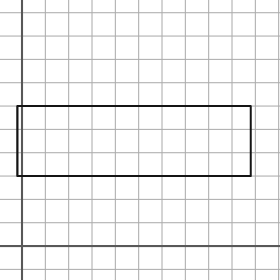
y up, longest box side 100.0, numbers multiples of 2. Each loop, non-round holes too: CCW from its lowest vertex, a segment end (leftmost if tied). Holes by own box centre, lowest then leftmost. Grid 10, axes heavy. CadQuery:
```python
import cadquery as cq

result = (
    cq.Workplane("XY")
    .moveTo(-2.0, 30.0)
    .lineTo(98.0, 30.0)
    .lineTo(98.0, 60.0)
    .lineTo(-2.0, 60.0)
    .close()
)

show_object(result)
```